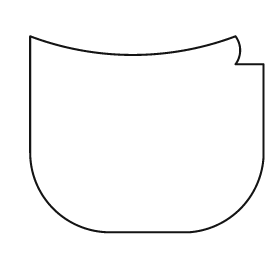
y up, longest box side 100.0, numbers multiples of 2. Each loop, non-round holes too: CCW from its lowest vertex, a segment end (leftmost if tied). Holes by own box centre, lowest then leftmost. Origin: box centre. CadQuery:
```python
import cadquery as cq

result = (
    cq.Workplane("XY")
    .moveTo(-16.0, -42.0)
    .lineTo(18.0, -42.0)
    .threePointArc((40.0, -32.0), (50.0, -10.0))
    .lineTo(50.0, 30.0)
    .lineTo(38.0, 30.0)
    .threePointArc((40.0, 36.0), (38.0, 42.0))
    .threePointArc((-6.0, 34.0), (-50.0, 42.0))
    .lineTo(-50.0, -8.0)
    .threePointArc((-40.0, -32.0), (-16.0, -42.0))
    .close()
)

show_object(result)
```